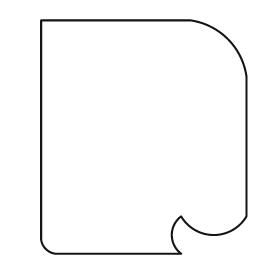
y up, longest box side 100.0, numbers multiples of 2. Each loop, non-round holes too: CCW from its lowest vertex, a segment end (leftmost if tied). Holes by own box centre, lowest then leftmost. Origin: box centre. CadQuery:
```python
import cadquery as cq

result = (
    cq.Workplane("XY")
    .moveTo(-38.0, -50.0)
    .lineTo(16.0, -50.0)
    .threePointArc((12.0, -42.0), (16.0, -34.0))
    .threePointArc((30.0, -42.0), (44.0, -34.0))
    .lineTo(44.0, 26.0)
    .threePointArc((36.0, 42.0), (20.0, 50.0))
    .lineTo(-44.0, 50.0)
    .lineTo(-44.0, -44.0)
    .threePointArc((-42.0, -48.0), (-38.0, -50.0))
    .close()
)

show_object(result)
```